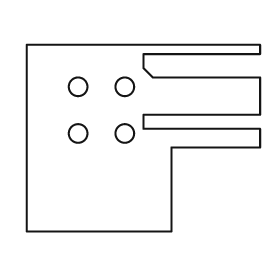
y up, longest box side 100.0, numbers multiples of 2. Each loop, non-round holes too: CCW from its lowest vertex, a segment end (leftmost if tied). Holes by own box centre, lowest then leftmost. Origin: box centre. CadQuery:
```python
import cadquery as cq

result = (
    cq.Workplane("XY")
    .moveTo(-50.0, -40.0)
    .lineTo(12.0, -40.0)
    .lineTo(12.0, -4.0)
    .lineTo(50.0, -4.0)
    .lineTo(50.0, 4.0)
    .lineTo(0.0, 4.0)
    .lineTo(0.0, 10.0)
    .lineTo(50.0, 10.0)
    .lineTo(50.0, 26.0)
    .lineTo(4.0, 26.0)
    .lineTo(0.0, 30.0)
    .lineTo(0.0, 36.0)
    .lineTo(50.0, 36.0)
    .lineTo(50.0, 40.0)
    .lineTo(-50.0, 40.0)
    .close()
    .moveTo(-28.0, 2.0)
    .circle(4.0)
    .moveTo(-8.0, 2.0)
    .circle(4.0)
    .moveTo(-28.0, 22.0)
    .circle(4.0)
    .moveTo(-8.0, 22.0)
    .circle(4.0)
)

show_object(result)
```